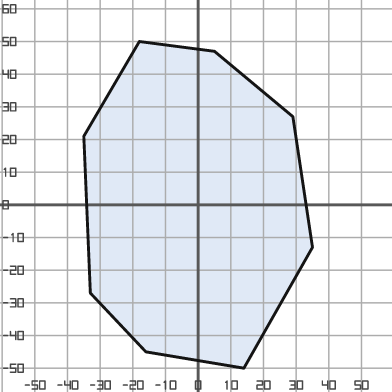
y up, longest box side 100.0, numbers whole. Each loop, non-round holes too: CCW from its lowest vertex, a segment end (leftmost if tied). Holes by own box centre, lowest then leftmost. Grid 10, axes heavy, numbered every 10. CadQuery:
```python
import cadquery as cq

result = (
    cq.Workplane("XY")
    .moveTo(14.0, -50.0)
    .lineTo(35.0, -13.0)
    .lineTo(29.0, 27.0)
    .lineTo(5.0, 47.0)
    .lineTo(-18.0, 50.0)
    .lineTo(-35.0, 21.0)
    .lineTo(-33.0, -27.0)
    .lineTo(-16.0, -45.0)
    .close()
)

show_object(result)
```